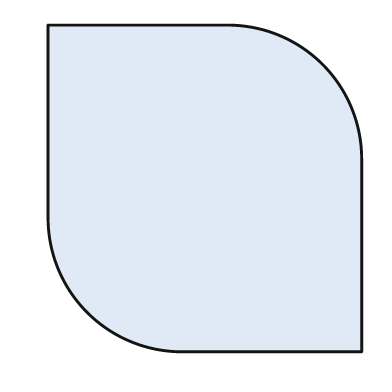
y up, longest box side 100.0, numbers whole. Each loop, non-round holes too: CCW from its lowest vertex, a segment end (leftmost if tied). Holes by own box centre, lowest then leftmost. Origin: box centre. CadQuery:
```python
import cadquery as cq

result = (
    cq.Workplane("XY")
    .moveTo(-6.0, -50.0)
    .lineTo(48.0, -50.0)
    .lineTo(48.0, 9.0)
    .threePointArc((36.0, 38.0), (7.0, 50.0))
    .lineTo(-48.0, 50.0)
    .lineTo(-48.0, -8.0)
    .threePointArc((-36.0, -38.0), (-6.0, -50.0))
    .close()
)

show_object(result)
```